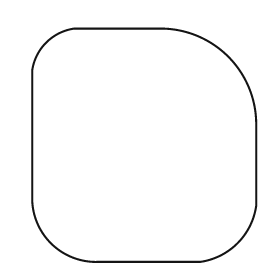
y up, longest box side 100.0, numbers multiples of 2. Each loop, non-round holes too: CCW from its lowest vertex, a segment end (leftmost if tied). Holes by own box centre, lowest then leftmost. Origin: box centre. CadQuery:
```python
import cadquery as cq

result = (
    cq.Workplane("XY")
    .moveTo(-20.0, -50.0)
    .lineTo(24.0, -50.0)
    .threePointArc((40.0, -42.0), (48.0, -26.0))
    .lineTo(48.0, 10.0)
    .threePointArc((36.0, 38.0), (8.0, 50.0))
    .lineTo(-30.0, 50.0)
    .threePointArc((-42.0, 44.0), (-48.0, 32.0))
    .lineTo(-48.0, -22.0)
    .threePointArc((-40.0, -42.0), (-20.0, -50.0))
    .close()
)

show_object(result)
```